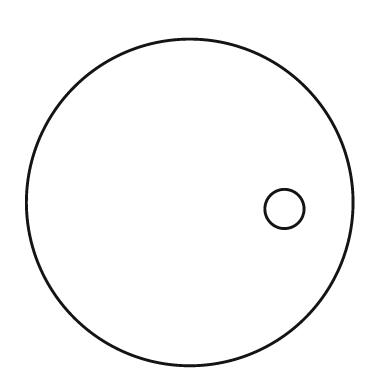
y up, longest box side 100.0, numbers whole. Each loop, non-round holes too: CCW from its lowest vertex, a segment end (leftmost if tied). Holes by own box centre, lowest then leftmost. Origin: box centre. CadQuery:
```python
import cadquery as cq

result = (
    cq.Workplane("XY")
    .moveTo(0.0, 0.0)
    .circle(50.0)
    .moveTo(29.0, -2.0)
    .circle(6.0)
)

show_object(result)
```